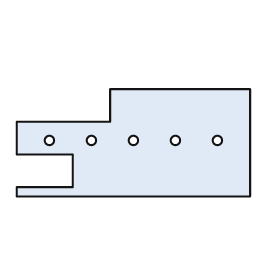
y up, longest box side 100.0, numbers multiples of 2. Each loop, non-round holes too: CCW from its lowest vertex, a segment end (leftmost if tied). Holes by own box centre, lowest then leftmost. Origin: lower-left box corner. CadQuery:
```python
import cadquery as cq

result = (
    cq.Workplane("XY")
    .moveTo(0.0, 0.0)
    .lineTo(100.0, 0.0)
    .lineTo(100.0, 46.0)
    .lineTo(40.0, 46.0)
    .lineTo(40.0, 32.0)
    .lineTo(0.0, 32.0)
    .lineTo(0.0, 18.0)
    .lineTo(24.0, 18.0)
    .lineTo(24.0, 4.0)
    .lineTo(0.0, 4.0)
    .close()
    .moveTo(14.0, 24.0)
    .circle(2.0)
    .moveTo(32.0, 24.0)
    .circle(2.0)
    .moveTo(50.0, 24.0)
    .circle(2.0)
    .moveTo(68.0, 24.0)
    .circle(2.0)
    .moveTo(86.0, 24.0)
    .circle(2.0)
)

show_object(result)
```